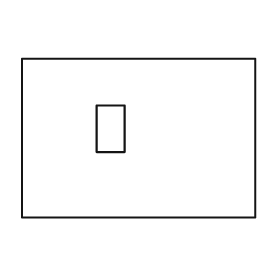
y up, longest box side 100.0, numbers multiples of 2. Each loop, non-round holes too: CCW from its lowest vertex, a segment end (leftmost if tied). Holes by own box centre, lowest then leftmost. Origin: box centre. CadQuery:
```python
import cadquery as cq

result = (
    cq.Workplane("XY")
    .moveTo(-50.0, -34.0)
    .lineTo(50.0, -34.0)
    .lineTo(50.0, 34.0)
    .lineTo(-50.0, 34.0)
    .close()
    .moveTo(-18.0, -6.0)
    .lineTo(-6.0, -6.0)
    .lineTo(-6.0, 14.0)
    .lineTo(-18.0, 14.0)
    .close()
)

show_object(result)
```